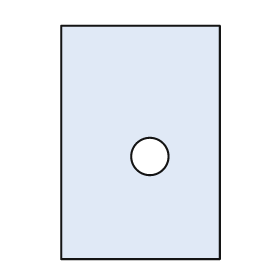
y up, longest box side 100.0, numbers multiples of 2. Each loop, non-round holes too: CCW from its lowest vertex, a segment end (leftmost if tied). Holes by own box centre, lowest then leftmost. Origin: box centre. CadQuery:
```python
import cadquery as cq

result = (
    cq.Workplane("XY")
    .moveTo(-34.0, -50.0)
    .lineTo(34.0, -50.0)
    .lineTo(34.0, 50.0)
    .lineTo(-34.0, 50.0)
    .close()
    .moveTo(4.0, -6.0)
    .circle(8.0)
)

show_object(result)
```